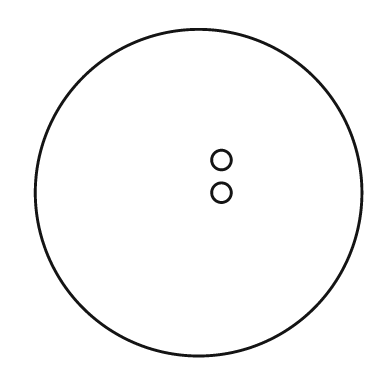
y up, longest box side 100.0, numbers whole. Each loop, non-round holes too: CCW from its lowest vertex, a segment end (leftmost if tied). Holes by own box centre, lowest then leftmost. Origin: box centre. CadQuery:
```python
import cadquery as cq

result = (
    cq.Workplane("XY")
    .moveTo(0.0, 0.0)
    .circle(50.0)
    .moveTo(7.0, 0.0)
    .circle(3.0)
    .moveTo(7.0, 10.0)
    .circle(3.0)
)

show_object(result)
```